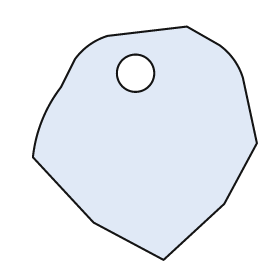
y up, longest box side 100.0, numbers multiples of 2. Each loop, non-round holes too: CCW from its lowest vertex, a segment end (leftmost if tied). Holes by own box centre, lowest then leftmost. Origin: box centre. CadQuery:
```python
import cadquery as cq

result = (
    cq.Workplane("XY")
    .moveTo(8.0, -50.0)
    .lineTo(34.0, -26.0)
    .lineTo(48.0, 0.0)
    .lineTo(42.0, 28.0)
    .threePointArc((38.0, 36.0), (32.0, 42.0))
    .lineTo(18.0, 50.0)
    .lineTo(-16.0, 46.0)
    .threePointArc((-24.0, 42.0), (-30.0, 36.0))
    .lineTo(-36.0, 24.0)
    .threePointArc((-44.0, 10.0), (-48.0, -6.0))
    .lineTo(-22.0, -34.0)
    .close()
    .moveTo(-4.0, 30.0)
    .circle(8.0)
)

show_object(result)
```